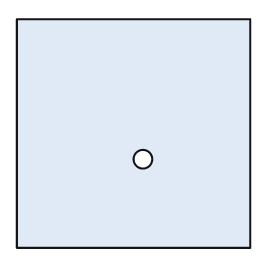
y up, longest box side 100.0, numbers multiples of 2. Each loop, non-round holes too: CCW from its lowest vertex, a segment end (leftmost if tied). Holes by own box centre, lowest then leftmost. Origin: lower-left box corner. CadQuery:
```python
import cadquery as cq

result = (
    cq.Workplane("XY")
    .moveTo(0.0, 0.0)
    .lineTo(100.0, 0.0)
    .lineTo(100.0, 98.0)
    .lineTo(0.0, 98.0)
    .close()
    .moveTo(54.0, 38.0)
    .circle(4.0)
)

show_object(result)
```